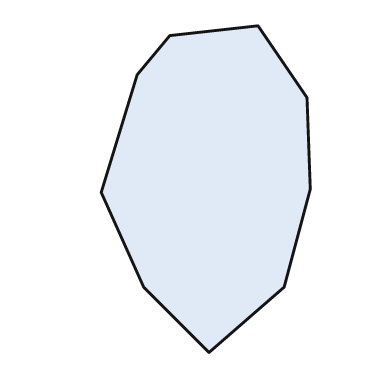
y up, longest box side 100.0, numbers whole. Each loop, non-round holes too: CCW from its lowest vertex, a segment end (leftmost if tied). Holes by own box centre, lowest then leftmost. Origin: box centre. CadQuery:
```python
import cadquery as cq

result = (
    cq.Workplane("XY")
    .moveTo(1.0, -50.0)
    .lineTo(24.0, -30.0)
    .lineTo(32.0, 0.0)
    .lineTo(31.0, 28.0)
    .lineTo(16.0, 50.0)
    .lineTo(-11.0, 47.0)
    .lineTo(-21.0, 35.0)
    .lineTo(-32.0, -1.0)
    .lineTo(-19.0, -30.0)
    .close()
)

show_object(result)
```